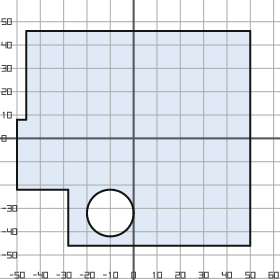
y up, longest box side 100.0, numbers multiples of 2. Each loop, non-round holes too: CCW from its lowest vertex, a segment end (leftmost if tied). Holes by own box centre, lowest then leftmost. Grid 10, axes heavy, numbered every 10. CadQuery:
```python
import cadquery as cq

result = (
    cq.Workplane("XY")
    .moveTo(-28.0, -46.0)
    .lineTo(50.0, -46.0)
    .lineTo(50.0, 46.0)
    .lineTo(-46.0, 46.0)
    .lineTo(-46.0, 8.0)
    .lineTo(-50.0, 8.0)
    .lineTo(-50.0, -22.0)
    .lineTo(-28.0, -22.0)
    .close()
    .moveTo(-10.0, -32.0)
    .circle(10.0)
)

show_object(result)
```